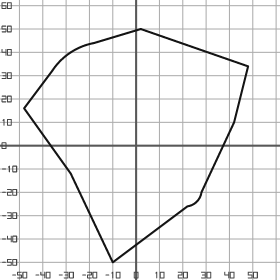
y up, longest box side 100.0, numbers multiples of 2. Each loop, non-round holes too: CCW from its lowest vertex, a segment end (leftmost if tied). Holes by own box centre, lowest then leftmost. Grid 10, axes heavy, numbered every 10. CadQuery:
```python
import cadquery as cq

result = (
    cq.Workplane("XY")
    .moveTo(-10.0, -50.0)
    .lineTo(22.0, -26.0)
    .threePointArc((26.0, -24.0), (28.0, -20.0))
    .lineTo(42.0, 10.0)
    .lineTo(48.0, 34.0)
    .lineTo(2.0, 50.0)
    .lineTo(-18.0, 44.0)
    .threePointArc((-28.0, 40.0), (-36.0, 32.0))
    .lineTo(-48.0, 16.0)
    .lineTo(-28.0, -12.0)
    .close()
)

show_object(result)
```